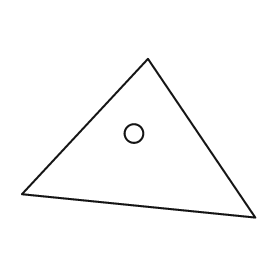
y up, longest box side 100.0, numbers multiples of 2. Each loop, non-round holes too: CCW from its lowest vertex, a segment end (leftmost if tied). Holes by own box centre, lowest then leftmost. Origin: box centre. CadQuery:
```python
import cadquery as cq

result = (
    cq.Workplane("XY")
    .moveTo(50.0, -34.0)
    .lineTo(4.0, 34.0)
    .lineTo(-50.0, -24.0)
    .close()
    .moveTo(-2.0, 2.0)
    .circle(4.0)
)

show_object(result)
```